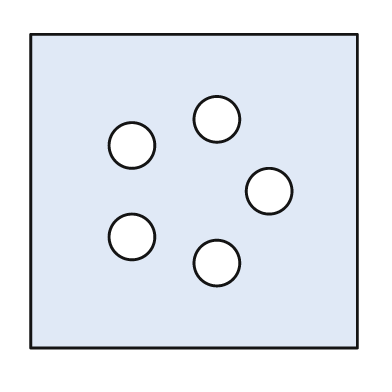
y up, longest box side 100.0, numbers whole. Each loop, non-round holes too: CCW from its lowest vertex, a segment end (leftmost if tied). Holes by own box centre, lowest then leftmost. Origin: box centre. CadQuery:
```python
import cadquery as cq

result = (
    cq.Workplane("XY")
    .moveTo(-50.0, -48.0)
    .lineTo(50.0, -48.0)
    .lineTo(50.0, 48.0)
    .lineTo(-50.0, 48.0)
    .close()
    .moveTo(7.0, -22.0)
    .circle(7.0)
    .moveTo(-19.0, -14.0)
    .circle(7.0)
    .moveTo(23.0, 0.0)
    .circle(7.0)
    .moveTo(-19.0, 14.0)
    .circle(7.0)
    .moveTo(7.0, 22.0)
    .circle(7.0)
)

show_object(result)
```